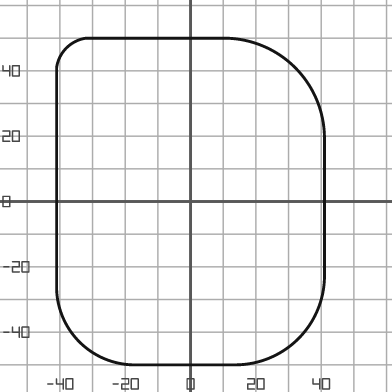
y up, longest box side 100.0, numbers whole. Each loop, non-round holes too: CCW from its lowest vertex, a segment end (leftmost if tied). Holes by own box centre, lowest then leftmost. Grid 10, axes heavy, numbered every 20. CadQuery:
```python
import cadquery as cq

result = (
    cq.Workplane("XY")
    .moveTo(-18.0, -50.0)
    .lineTo(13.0, -50.0)
    .threePointArc((33.0, -42.0), (41.0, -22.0))
    .lineTo(41.0, 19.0)
    .threePointArc((32.0, 41.0), (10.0, 50.0))
    .lineTo(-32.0, 50.0)
    .threePointArc((-38.0, 47.0), (-41.0, 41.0))
    .lineTo(-41.0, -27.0)
    .threePointArc((-34.0, -43.0), (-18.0, -50.0))
    .close()
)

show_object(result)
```